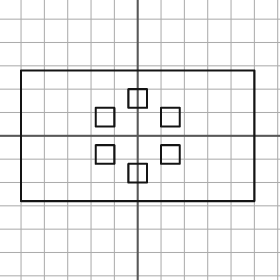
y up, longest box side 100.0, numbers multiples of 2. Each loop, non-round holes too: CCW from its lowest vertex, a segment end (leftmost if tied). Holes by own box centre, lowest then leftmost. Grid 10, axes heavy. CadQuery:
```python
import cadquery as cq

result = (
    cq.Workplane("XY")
    .moveTo(-50.0, -28.0)
    .lineTo(50.0, -28.0)
    .lineTo(50.0, 28.0)
    .lineTo(-50.0, 28.0)
    .close()
    .moveTo(-4.0, -20.0)
    .lineTo(4.0, -20.0)
    .lineTo(4.0, -12.0)
    .lineTo(-4.0, -12.0)
    .close()
    .moveTo(-18.0, -12.0)
    .lineTo(-10.0, -12.0)
    .lineTo(-10.0, -4.0)
    .lineTo(-18.0, -4.0)
    .close()
    .moveTo(10.0, -12.0)
    .lineTo(18.0, -12.0)
    .lineTo(18.0, -4.0)
    .lineTo(10.0, -4.0)
    .close()
    .moveTo(-18.0, 4.0)
    .lineTo(-10.0, 4.0)
    .lineTo(-10.0, 12.0)
    .lineTo(-18.0, 12.0)
    .close()
    .moveTo(10.0, 4.0)
    .lineTo(18.0, 4.0)
    .lineTo(18.0, 12.0)
    .lineTo(10.0, 12.0)
    .close()
    .moveTo(-4.0, 12.0)
    .lineTo(4.0, 12.0)
    .lineTo(4.0, 20.0)
    .lineTo(-4.0, 20.0)
    .close()
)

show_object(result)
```